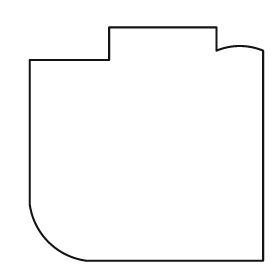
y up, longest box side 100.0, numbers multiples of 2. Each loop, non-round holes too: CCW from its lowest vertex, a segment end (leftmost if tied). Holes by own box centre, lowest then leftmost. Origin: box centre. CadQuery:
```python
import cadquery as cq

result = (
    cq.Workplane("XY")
    .moveTo(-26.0, -50.0)
    .lineTo(50.0, -50.0)
    .lineTo(50.0, 40.0)
    .threePointArc((40.0, 42.0), (30.0, 40.0))
    .lineTo(30.0, 50.0)
    .lineTo(-16.0, 50.0)
    .lineTo(-16.0, 36.0)
    .lineTo(-50.0, 36.0)
    .lineTo(-50.0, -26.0)
    .threePointArc((-42.0, -42.0), (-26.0, -50.0))
    .close()
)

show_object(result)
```